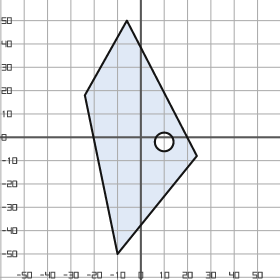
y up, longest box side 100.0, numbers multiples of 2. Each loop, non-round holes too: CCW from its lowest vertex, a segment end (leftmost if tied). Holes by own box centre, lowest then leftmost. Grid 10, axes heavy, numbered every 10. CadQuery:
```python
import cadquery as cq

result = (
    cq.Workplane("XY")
    .moveTo(-10.0, -50.0)
    .lineTo(24.0, -8.0)
    .lineTo(-6.0, 50.0)
    .lineTo(-24.0, 18.0)
    .close()
    .moveTo(10.0, -2.0)
    .circle(4.0)
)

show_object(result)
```